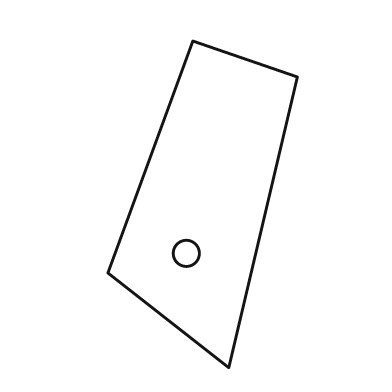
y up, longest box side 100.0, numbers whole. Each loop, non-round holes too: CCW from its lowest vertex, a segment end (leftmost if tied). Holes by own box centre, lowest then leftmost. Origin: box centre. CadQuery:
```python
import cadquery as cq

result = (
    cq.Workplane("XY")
    .moveTo(8.0, -50.0)
    .lineTo(29.0, 39.0)
    .lineTo(-3.0, 50.0)
    .lineTo(-29.0, -21.0)
    .close()
    .moveTo(-5.0, -15.0)
    .circle(4.0)
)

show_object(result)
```